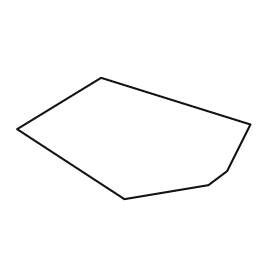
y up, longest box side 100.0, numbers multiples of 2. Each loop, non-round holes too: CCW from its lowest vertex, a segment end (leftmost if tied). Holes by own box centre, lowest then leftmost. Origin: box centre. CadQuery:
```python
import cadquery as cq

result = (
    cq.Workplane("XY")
    .moveTo(-4.0, -26.0)
    .lineTo(32.0, -20.0)
    .lineTo(40.0, -14.0)
    .lineTo(50.0, 6.0)
    .lineTo(-14.0, 26.0)
    .lineTo(-50.0, 4.0)
    .close()
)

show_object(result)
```